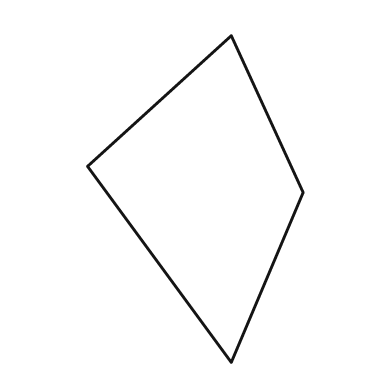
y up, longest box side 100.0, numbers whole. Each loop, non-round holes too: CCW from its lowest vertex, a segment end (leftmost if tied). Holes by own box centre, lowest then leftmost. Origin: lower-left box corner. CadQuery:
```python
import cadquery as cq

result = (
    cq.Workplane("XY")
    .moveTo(44.0, 0.0)
    .lineTo(66.0, 52.0)
    .lineTo(44.0, 100.0)
    .lineTo(0.0, 60.0)
    .close()
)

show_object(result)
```